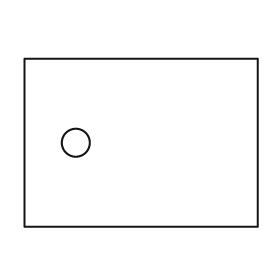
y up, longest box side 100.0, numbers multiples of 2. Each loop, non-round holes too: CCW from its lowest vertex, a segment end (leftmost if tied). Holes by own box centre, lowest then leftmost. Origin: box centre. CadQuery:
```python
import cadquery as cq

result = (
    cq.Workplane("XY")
    .moveTo(-50.0, -36.0)
    .lineTo(50.0, -36.0)
    .lineTo(50.0, 36.0)
    .lineTo(-50.0, 36.0)
    .close()
    .moveTo(-28.0, 0.0)
    .circle(6.0)
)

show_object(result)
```